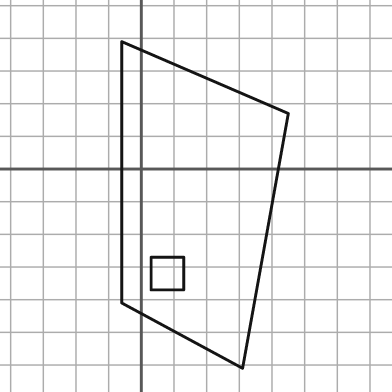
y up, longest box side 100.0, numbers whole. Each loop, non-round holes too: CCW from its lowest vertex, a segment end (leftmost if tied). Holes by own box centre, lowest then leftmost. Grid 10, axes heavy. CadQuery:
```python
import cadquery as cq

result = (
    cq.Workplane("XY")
    .moveTo(31.0, -61.0)
    .lineTo(45.0, 17.0)
    .lineTo(-6.0, 39.0)
    .lineTo(-6.0, -41.0)
    .close()
    .moveTo(3.0, -37.0)
    .lineTo(13.0, -37.0)
    .lineTo(13.0, -27.0)
    .lineTo(3.0, -27.0)
    .close()
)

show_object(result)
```